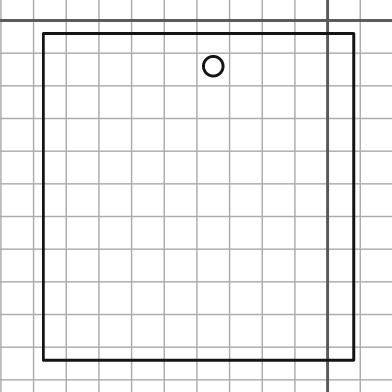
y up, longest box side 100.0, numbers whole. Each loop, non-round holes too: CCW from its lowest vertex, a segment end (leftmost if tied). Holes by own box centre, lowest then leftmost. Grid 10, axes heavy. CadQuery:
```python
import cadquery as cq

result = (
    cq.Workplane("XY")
    .moveTo(-87.0, -104.0)
    .lineTo(8.0, -104.0)
    .lineTo(8.0, -4.0)
    .lineTo(-87.0, -4.0)
    .close()
    .moveTo(-35.0, -14.0)
    .circle(3.0)
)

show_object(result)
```